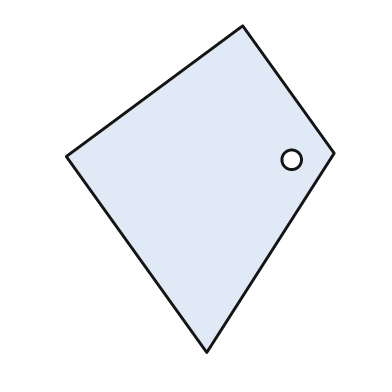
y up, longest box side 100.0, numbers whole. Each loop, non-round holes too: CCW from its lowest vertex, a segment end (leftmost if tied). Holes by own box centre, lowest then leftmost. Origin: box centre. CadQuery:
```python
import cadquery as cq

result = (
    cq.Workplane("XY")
    .moveTo(2.0, -50.0)
    .lineTo(41.0, 11.0)
    .lineTo(13.0, 50.0)
    .lineTo(-41.0, 10.0)
    .close()
    .moveTo(28.0, 9.0)
    .circle(3.0)
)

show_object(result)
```